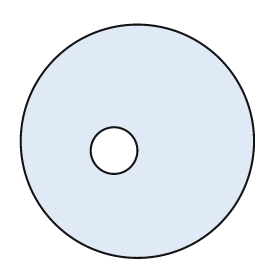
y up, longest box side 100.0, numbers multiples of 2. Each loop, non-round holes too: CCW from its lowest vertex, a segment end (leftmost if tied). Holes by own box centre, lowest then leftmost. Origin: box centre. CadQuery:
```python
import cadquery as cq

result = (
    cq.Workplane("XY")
    .moveTo(0.0, 0.0)
    .circle(50.0)
    .moveTo(-10.0, -4.0)
    .circle(10.0)
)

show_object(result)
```